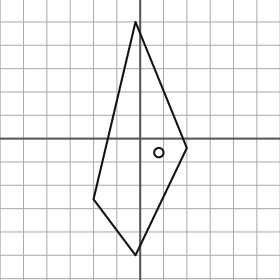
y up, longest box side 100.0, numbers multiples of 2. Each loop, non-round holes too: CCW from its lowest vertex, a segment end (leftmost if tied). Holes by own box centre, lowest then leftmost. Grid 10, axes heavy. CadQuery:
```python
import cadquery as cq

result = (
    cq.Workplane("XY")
    .moveTo(-2.0, -50.0)
    .lineTo(20.0, -4.0)
    .lineTo(-2.0, 50.0)
    .lineTo(-20.0, -26.0)
    .close()
    .moveTo(8.0, -6.0)
    .circle(2.0)
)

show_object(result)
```